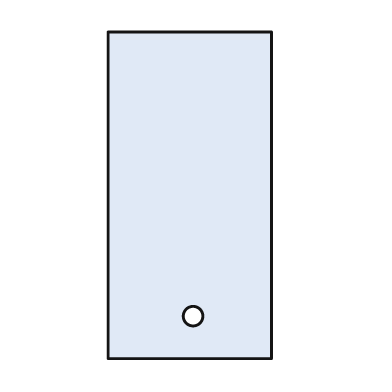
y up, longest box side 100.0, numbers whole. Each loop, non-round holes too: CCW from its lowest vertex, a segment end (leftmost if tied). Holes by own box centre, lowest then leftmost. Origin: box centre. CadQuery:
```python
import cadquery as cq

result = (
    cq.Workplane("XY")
    .moveTo(-25.0, -50.0)
    .lineTo(25.0, -50.0)
    .lineTo(25.0, 50.0)
    .lineTo(-25.0, 50.0)
    .close()
    .moveTo(1.0, -37.0)
    .circle(3.0)
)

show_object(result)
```